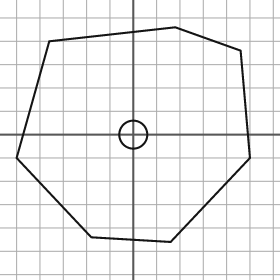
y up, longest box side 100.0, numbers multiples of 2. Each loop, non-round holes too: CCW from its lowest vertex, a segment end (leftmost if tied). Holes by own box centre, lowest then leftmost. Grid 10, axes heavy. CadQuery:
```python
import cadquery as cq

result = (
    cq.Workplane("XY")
    .moveTo(16.0, -46.0)
    .lineTo(50.0, -10.0)
    .lineTo(46.0, 36.0)
    .lineTo(18.0, 46.0)
    .lineTo(-36.0, 40.0)
    .lineTo(-50.0, -10.0)
    .lineTo(-18.0, -44.0)
    .close()
    .moveTo(0.0, 0.0)
    .circle(6.0)
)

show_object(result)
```